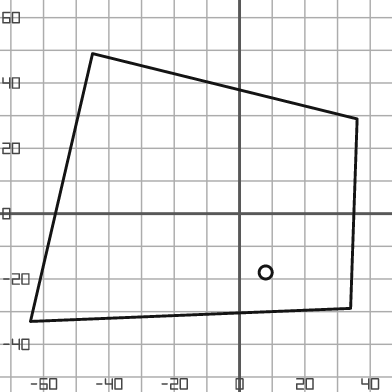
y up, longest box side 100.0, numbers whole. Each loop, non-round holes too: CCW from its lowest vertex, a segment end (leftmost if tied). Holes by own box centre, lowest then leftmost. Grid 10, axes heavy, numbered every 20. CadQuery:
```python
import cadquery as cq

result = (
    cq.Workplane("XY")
    .moveTo(-64.0, -33.0)
    .lineTo(34.0, -29.0)
    .lineTo(36.0, 29.0)
    .lineTo(-45.0, 49.0)
    .close()
    .moveTo(8.0, -18.0)
    .circle(2.0)
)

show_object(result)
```